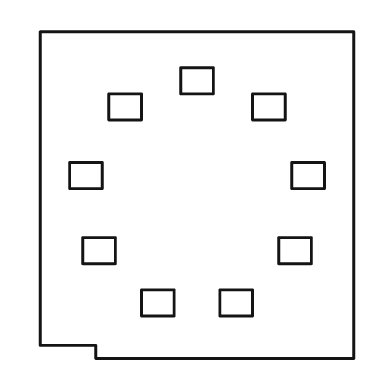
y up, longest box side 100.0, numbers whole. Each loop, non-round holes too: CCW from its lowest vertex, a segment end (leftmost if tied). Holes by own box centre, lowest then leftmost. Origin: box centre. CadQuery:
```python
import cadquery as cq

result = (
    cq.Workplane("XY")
    .moveTo(-31.0, -50.0)
    .lineTo(48.0, -50.0)
    .lineTo(48.0, 50.0)
    .lineTo(-48.0, 50.0)
    .lineTo(-48.0, -46.0)
    .lineTo(-31.0, -46.0)
    .close()
    .moveTo(-17.0, -37.0)
    .lineTo(-7.0, -37.0)
    .lineTo(-7.0, -29.0)
    .lineTo(-17.0, -29.0)
    .close()
    .moveTo(7.0, -37.0)
    .lineTo(17.0, -37.0)
    .lineTo(17.0, -29.0)
    .lineTo(7.0, -29.0)
    .close()
    .moveTo(-35.0, -21.0)
    .lineTo(-25.0, -21.0)
    .lineTo(-25.0, -13.0)
    .lineTo(-35.0, -13.0)
    .close()
    .moveTo(25.0, -21.0)
    .lineTo(35.0, -21.0)
    .lineTo(35.0, -13.0)
    .lineTo(25.0, -13.0)
    .close()
    .moveTo(-39.0, 2.0)
    .lineTo(-29.0, 2.0)
    .lineTo(-29.0, 10.0)
    .lineTo(-39.0, 10.0)
    .close()
    .moveTo(29.0, 2.0)
    .lineTo(39.0, 2.0)
    .lineTo(39.0, 10.0)
    .lineTo(29.0, 10.0)
    .close()
    .moveTo(-27.0, 23.0)
    .lineTo(-17.0, 23.0)
    .lineTo(-17.0, 31.0)
    .lineTo(-27.0, 31.0)
    .close()
    .moveTo(17.0, 23.0)
    .lineTo(27.0, 23.0)
    .lineTo(27.0, 31.0)
    .lineTo(17.0, 31.0)
    .close()
    .moveTo(-5.0, 31.0)
    .lineTo(5.0, 31.0)
    .lineTo(5.0, 39.0)
    .lineTo(-5.0, 39.0)
    .close()
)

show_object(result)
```